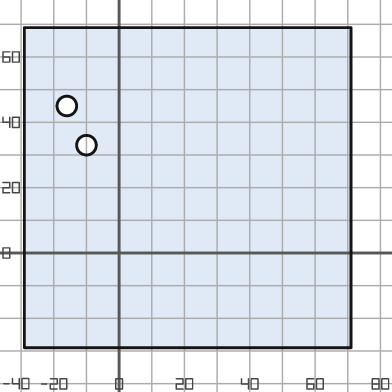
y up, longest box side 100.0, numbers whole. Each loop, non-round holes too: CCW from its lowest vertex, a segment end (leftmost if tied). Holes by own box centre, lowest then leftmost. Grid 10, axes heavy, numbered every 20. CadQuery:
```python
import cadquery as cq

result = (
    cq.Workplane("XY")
    .moveTo(-29.0, -29.0)
    .lineTo(71.0, -29.0)
    .lineTo(71.0, 69.0)
    .lineTo(-29.0, 69.0)
    .close()
    .moveTo(-10.0, 33.0)
    .circle(3.0)
    .moveTo(-16.0, 45.0)
    .circle(3.0)
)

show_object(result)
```